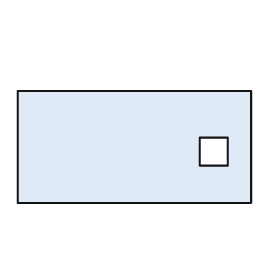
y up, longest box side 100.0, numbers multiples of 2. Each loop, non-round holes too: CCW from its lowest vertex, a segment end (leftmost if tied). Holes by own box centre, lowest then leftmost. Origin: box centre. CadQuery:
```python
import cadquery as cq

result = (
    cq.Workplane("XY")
    .moveTo(-50.0, -24.0)
    .lineTo(50.0, -24.0)
    .lineTo(50.0, 24.0)
    .lineTo(-50.0, 24.0)
    .close()
    .moveTo(28.0, -8.0)
    .lineTo(40.0, -8.0)
    .lineTo(40.0, 4.0)
    .lineTo(28.0, 4.0)
    .close()
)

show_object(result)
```